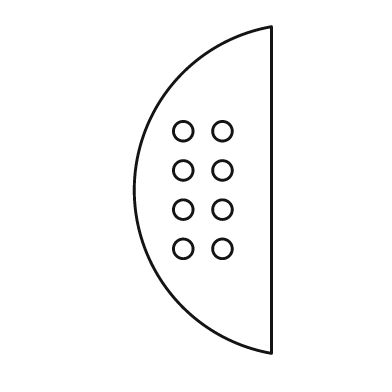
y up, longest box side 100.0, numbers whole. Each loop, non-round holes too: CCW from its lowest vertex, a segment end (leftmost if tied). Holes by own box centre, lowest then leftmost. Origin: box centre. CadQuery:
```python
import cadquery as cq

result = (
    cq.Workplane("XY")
    .moveTo(21.0, -50.0)
    .lineTo(21.0, 50.0)
    .threePointArc((-21.0, 0.0), (21.0, -50.0))
    .close()
    .moveTo(-6.0, -18.0)
    .circle(3.0)
    .moveTo(6.0, -18.0)
    .circle(3.0)
    .moveTo(-6.0, -6.0)
    .circle(3.0)
    .moveTo(6.0, -6.0)
    .circle(3.0)
    .moveTo(-6.0, 6.0)
    .circle(3.0)
    .moveTo(6.0, 6.0)
    .circle(3.0)
    .moveTo(-6.0, 18.0)
    .circle(3.0)
    .moveTo(6.0, 18.0)
    .circle(3.0)
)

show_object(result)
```